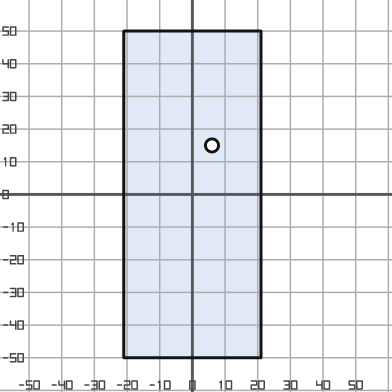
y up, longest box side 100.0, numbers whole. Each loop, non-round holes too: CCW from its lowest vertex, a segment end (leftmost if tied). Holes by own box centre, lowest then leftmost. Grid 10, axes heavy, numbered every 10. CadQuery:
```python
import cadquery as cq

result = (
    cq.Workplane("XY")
    .moveTo(-21.0, -50.0)
    .lineTo(21.0, -50.0)
    .lineTo(21.0, 50.0)
    .lineTo(-21.0, 50.0)
    .close()
    .moveTo(6.0, 15.0)
    .circle(2.0)
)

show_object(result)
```